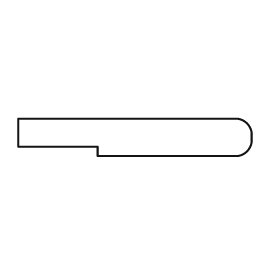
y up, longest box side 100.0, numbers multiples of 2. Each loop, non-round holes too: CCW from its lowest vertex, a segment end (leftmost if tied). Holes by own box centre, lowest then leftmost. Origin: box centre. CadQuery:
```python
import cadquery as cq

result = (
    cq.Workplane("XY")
    .moveTo(-16.0, -8.0)
    .lineTo(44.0, -8.0)
    .threePointArc((48.0, -6.0), (50.0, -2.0))
    .lineTo(50.0, 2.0)
    .threePointArc((48.0, 6.0), (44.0, 8.0))
    .lineTo(-50.0, 8.0)
    .lineTo(-50.0, -4.0)
    .lineTo(-16.0, -4.0)
    .close()
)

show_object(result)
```